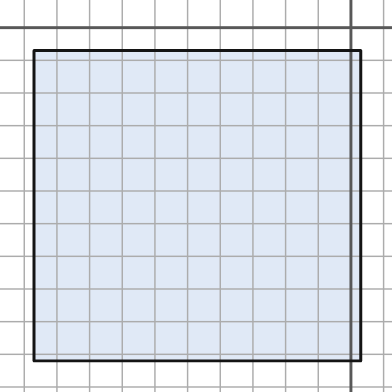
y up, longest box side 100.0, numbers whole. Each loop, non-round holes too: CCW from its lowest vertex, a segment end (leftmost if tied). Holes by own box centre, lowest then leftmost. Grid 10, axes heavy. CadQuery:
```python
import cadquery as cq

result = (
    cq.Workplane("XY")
    .moveTo(-97.0, -102.0)
    .lineTo(3.0, -102.0)
    .lineTo(3.0, -7.0)
    .lineTo(-97.0, -7.0)
    .close()
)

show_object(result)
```